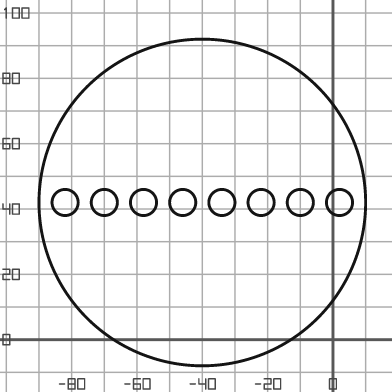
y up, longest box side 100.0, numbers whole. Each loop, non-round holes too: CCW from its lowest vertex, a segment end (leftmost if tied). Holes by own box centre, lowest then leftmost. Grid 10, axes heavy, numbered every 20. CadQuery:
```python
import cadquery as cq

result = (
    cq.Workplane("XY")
    .moveTo(-40.0, 42.0)
    .circle(50.0)
    .moveTo(-82.0, 42.0)
    .circle(4.0)
    .moveTo(-70.0, 42.0)
    .circle(4.0)
    .moveTo(-58.0, 42.0)
    .circle(4.0)
    .moveTo(-46.0, 42.0)
    .circle(4.0)
    .moveTo(-34.0, 42.0)
    .circle(4.0)
    .moveTo(-22.0, 42.0)
    .circle(4.0)
    .moveTo(-10.0, 42.0)
    .circle(4.0)
    .moveTo(2.0, 42.0)
    .circle(4.0)
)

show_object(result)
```